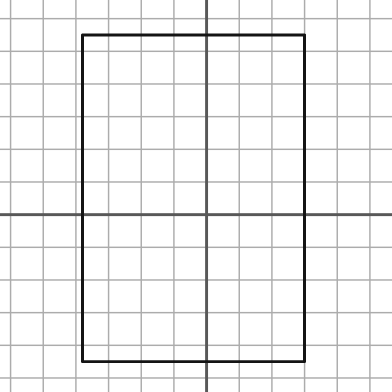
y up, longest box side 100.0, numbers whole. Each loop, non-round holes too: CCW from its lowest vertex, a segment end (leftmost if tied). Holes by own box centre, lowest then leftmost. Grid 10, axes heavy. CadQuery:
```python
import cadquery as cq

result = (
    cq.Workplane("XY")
    .moveTo(-38.0, -45.0)
    .lineTo(30.0, -45.0)
    .lineTo(30.0, 55.0)
    .lineTo(-38.0, 55.0)
    .close()
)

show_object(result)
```